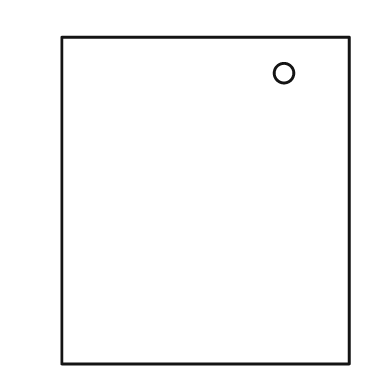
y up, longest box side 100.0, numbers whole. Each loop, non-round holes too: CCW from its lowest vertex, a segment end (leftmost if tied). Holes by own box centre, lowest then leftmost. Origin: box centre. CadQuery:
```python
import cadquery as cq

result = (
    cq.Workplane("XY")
    .moveTo(-44.0, -50.0)
    .lineTo(44.0, -50.0)
    .lineTo(44.0, 50.0)
    .lineTo(-44.0, 50.0)
    .close()
    .moveTo(24.0, 39.0)
    .circle(3.0)
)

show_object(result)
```